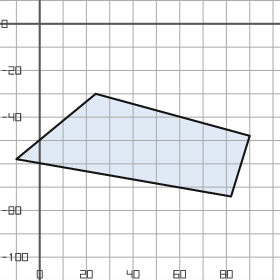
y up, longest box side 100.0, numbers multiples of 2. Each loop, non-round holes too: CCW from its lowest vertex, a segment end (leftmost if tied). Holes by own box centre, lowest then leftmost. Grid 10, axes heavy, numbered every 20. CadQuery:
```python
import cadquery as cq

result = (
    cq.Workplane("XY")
    .moveTo(82.0, -74.0)
    .lineTo(90.0, -48.0)
    .lineTo(24.0, -30.0)
    .lineTo(-10.0, -58.0)
    .close()
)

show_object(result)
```